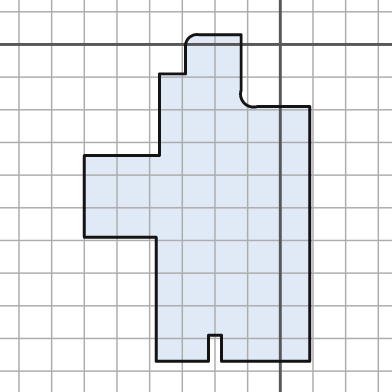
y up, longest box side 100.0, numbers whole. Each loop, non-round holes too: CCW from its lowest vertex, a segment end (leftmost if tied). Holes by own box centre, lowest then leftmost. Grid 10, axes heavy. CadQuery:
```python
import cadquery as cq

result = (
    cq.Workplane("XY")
    .moveTo(-38.0, -97.0)
    .lineTo(-22.0, -97.0)
    .lineTo(-22.0, -89.0)
    .lineTo(-18.0, -89.0)
    .lineTo(-18.0, -97.0)
    .lineTo(9.0, -97.0)
    .lineTo(9.0, -19.0)
    .lineTo(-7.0, -19.0)
    .threePointArc((-11.0, -18.0), (-12.0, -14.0))
    .lineTo(-12.0, 3.0)
    .lineTo(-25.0, 3.0)
    .threePointArc((-28.0, 2.0), (-29.0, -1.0))
    .lineTo(-29.0, -9.0)
    .lineTo(-37.0, -9.0)
    .lineTo(-37.0, -34.0)
    .lineTo(-60.0, -34.0)
    .lineTo(-60.0, -59.0)
    .lineTo(-38.0, -59.0)
    .close()
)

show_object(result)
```